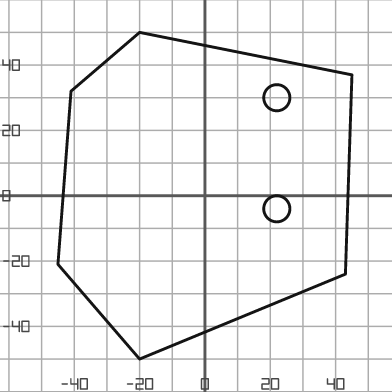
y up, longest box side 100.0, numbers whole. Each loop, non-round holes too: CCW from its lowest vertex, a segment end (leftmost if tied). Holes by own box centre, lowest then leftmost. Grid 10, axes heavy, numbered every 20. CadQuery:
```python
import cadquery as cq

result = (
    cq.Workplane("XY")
    .moveTo(-20.0, -50.0)
    .lineTo(43.0, -24.0)
    .lineTo(45.0, 37.0)
    .lineTo(-20.0, 50.0)
    .lineTo(-41.0, 32.0)
    .lineTo(-45.0, -21.0)
    .close()
    .moveTo(22.0, -4.0)
    .circle(4.0)
    .moveTo(22.0, 30.0)
    .circle(4.0)
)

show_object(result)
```